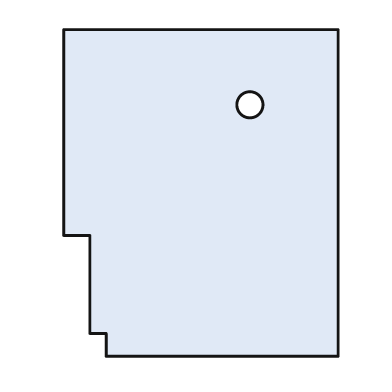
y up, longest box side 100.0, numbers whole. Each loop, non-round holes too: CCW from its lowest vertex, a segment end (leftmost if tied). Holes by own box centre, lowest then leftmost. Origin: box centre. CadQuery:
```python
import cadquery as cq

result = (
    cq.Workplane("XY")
    .moveTo(-29.0, -50.0)
    .lineTo(42.0, -50.0)
    .lineTo(42.0, 50.0)
    .lineTo(-42.0, 50.0)
    .lineTo(-42.0, -13.0)
    .lineTo(-34.0, -13.0)
    .lineTo(-34.0, -43.0)
    .lineTo(-29.0, -43.0)
    .close()
    .moveTo(15.0, 27.0)
    .circle(4.0)
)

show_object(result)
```